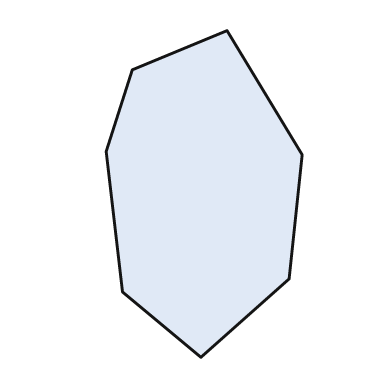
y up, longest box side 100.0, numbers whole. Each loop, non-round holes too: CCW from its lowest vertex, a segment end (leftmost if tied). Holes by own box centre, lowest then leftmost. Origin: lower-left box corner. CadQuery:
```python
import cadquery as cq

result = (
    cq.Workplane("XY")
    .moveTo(29.0, 0.0)
    .lineTo(56.0, 24.0)
    .lineTo(60.0, 62.0)
    .lineTo(37.0, 100.0)
    .lineTo(8.0, 88.0)
    .lineTo(0.0, 63.0)
    .lineTo(5.0, 20.0)
    .close()
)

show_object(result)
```